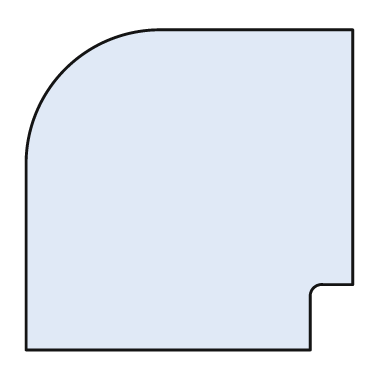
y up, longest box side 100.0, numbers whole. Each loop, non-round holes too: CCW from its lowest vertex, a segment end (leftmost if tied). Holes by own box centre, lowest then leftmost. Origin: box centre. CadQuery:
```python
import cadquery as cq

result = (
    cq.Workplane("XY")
    .moveTo(-50.0, -49.0)
    .lineTo(37.0, -49.0)
    .lineTo(37.0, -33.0)
    .threePointArc((38.0, -30.0), (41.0, -29.0))
    .lineTo(50.0, -29.0)
    .lineTo(50.0, 49.0)
    .lineTo(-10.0, 49.0)
    .threePointArc((-38.0, 37.0), (-50.0, 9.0))
    .close()
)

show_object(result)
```